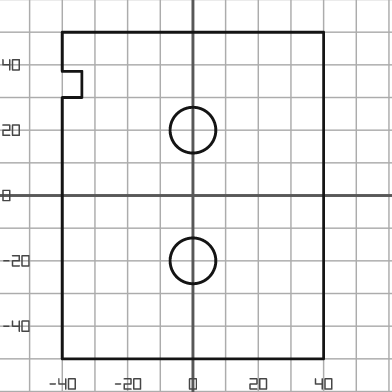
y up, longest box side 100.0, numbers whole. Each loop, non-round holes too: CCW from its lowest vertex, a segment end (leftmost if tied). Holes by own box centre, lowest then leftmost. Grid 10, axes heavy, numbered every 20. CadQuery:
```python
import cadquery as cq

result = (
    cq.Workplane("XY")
    .moveTo(-40.0, -50.0)
    .lineTo(40.0, -50.0)
    .lineTo(40.0, 50.0)
    .lineTo(-40.0, 50.0)
    .lineTo(-40.0, 38.0)
    .lineTo(-34.0, 38.0)
    .lineTo(-34.0, 30.0)
    .lineTo(-40.0, 30.0)
    .close()
    .moveTo(0.0, -20.0)
    .circle(7.0)
    .moveTo(0.0, 20.0)
    .circle(7.0)
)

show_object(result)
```